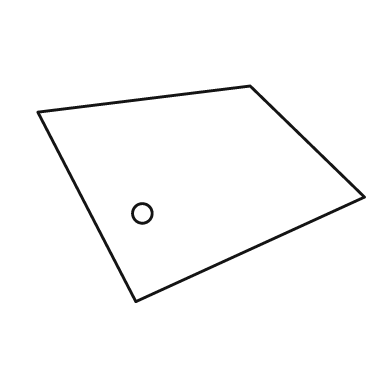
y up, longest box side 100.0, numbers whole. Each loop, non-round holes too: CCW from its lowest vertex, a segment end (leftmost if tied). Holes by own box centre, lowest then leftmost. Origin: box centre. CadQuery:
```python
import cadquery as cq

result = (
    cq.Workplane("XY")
    .moveTo(-20.0, -33.0)
    .lineTo(50.0, -1.0)
    .lineTo(15.0, 33.0)
    .lineTo(-50.0, 25.0)
    .close()
    .moveTo(-18.0, -6.0)
    .circle(3.0)
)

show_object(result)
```